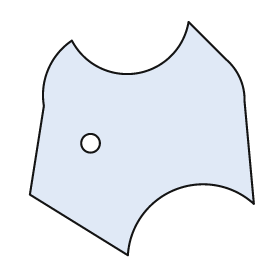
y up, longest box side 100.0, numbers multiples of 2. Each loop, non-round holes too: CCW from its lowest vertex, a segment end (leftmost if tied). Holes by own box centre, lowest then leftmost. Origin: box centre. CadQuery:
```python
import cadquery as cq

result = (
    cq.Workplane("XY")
    .moveTo(-6.0, -50.0)
    .threePointArc((14.0, -22.0), (48.0, -28.0))
    .lineTo(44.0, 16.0)
    .threePointArc((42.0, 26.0), (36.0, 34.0))
    .lineTo(20.0, 50.0)
    .threePointArc((-2.0, 28.0), (-30.0, 42.0))
    .threePointArc((-40.0, 30.0), (-42.0, 14.0))
    .lineTo(-48.0, -24.0)
    .close()
    .moveTo(-22.0, -2.0)
    .circle(4.0)
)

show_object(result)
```